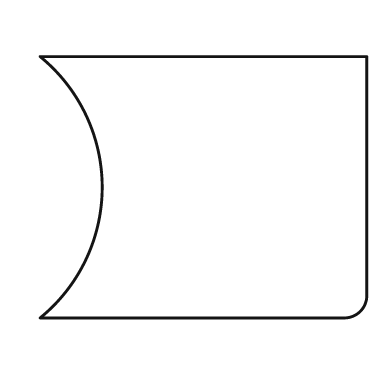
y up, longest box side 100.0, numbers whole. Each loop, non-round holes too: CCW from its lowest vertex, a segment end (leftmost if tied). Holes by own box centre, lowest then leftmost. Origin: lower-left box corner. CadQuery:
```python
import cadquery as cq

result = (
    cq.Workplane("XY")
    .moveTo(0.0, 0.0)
    .lineTo(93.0, 0.0)
    .threePointArc((98.0, 2.0), (100.0, 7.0))
    .lineTo(100.0, 80.0)
    .lineTo(0.0, 80.0)
    .threePointArc((19.0, 40.0), (0.0, 0.0))
    .close()
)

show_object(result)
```